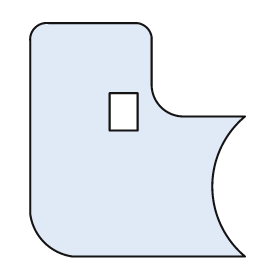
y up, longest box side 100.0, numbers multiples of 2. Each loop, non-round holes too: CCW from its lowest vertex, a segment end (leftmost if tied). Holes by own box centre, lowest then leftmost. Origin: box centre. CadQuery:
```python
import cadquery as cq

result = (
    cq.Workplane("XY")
    .moveTo(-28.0, -50.0)
    .lineTo(46.0, -50.0)
    .threePointArc((32.0, -20.0), (46.0, 10.0))
    .lineTo(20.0, 10.0)
    .threePointArc((10.0, 14.0), (6.0, 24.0))
    .lineTo(6.0, 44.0)
    .threePointArc((4.0, 48.0), (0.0, 50.0))
    .lineTo(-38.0, 50.0)
    .threePointArc((-44.0, 48.0), (-46.0, 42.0))
    .lineTo(-46.0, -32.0)
    .threePointArc((-40.0, -44.0), (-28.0, -50.0))
    .close()
    .moveTo(-12.0, 4.0)
    .lineTo(0.0, 4.0)
    .lineTo(0.0, 20.0)
    .lineTo(-12.0, 20.0)
    .close()
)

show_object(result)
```